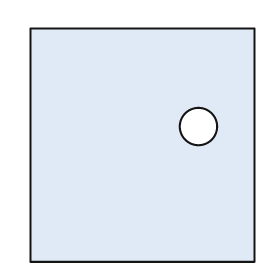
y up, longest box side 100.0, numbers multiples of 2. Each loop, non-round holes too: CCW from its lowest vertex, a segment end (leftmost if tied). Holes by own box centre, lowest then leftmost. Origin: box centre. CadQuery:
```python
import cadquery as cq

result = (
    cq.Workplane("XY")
    .moveTo(-48.0, -50.0)
    .lineTo(48.0, -50.0)
    .lineTo(48.0, 50.0)
    .lineTo(-48.0, 50.0)
    .close()
    .moveTo(24.0, 8.0)
    .circle(8.0)
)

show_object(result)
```